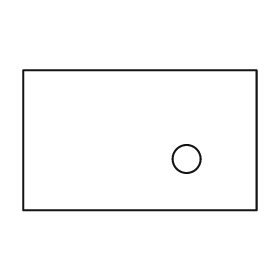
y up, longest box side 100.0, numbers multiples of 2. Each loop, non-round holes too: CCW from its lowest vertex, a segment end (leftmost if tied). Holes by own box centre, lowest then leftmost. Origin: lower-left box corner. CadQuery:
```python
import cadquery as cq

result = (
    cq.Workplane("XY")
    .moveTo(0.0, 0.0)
    .lineTo(100.0, 0.0)
    .lineTo(100.0, 60.0)
    .lineTo(0.0, 60.0)
    .close()
    .moveTo(70.0, 22.0)
    .circle(6.0)
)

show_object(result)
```